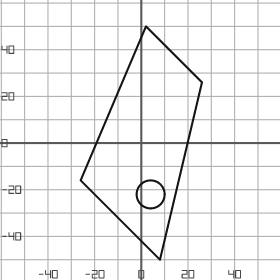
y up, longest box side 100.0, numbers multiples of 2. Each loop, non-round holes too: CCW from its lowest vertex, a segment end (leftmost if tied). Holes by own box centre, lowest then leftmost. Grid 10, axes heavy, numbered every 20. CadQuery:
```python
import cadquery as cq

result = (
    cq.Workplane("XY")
    .moveTo(8.0, -50.0)
    .lineTo(26.0, 26.0)
    .lineTo(2.0, 50.0)
    .lineTo(-26.0, -16.0)
    .close()
    .moveTo(4.0, -22.0)
    .circle(6.0)
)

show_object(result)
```